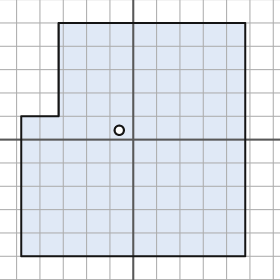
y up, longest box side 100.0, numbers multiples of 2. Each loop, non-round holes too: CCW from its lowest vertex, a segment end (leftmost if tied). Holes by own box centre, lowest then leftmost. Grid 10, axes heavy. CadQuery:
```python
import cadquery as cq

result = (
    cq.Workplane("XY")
    .moveTo(-48.0, -50.0)
    .lineTo(48.0, -50.0)
    .lineTo(48.0, 50.0)
    .lineTo(-32.0, 50.0)
    .lineTo(-32.0, 10.0)
    .lineTo(-48.0, 10.0)
    .close()
    .moveTo(-6.0, 4.0)
    .circle(2.0)
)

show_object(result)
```